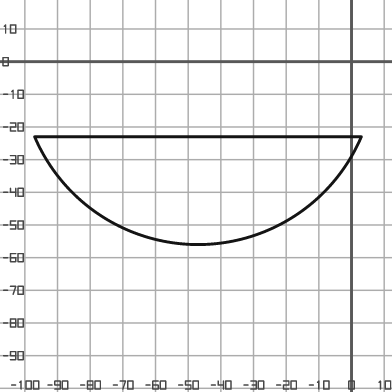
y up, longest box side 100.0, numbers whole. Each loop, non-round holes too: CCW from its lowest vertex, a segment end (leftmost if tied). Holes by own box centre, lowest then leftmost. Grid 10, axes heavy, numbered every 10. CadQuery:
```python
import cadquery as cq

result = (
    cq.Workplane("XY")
    .moveTo(-97.0, -23.0)
    .threePointArc((-47.0, -56.0), (3.0, -23.0))
    .close()
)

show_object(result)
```